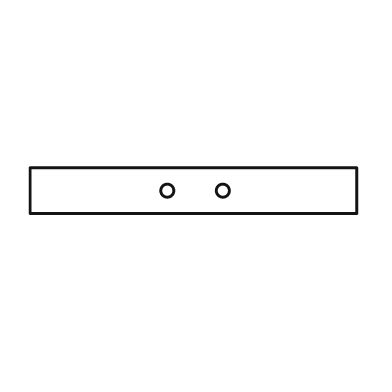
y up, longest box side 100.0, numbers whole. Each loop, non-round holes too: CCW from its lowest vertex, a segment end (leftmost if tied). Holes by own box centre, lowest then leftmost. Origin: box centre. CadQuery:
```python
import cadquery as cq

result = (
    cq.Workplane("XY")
    .moveTo(-50.0, -7.0)
    .lineTo(50.0, -7.0)
    .lineTo(50.0, 7.0)
    .lineTo(-50.0, 7.0)
    .close()
    .moveTo(-8.0, 0.0)
    .circle(2.0)
    .moveTo(9.0, 0.0)
    .circle(2.0)
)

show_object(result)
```